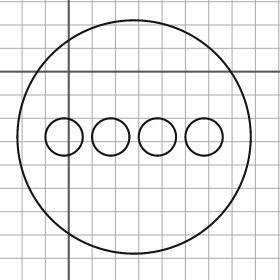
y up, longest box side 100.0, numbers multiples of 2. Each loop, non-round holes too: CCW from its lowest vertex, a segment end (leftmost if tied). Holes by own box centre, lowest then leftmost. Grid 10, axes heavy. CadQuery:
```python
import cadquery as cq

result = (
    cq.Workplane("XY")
    .moveTo(28.0, -28.0)
    .circle(50.0)
    .moveTo(-2.0, -28.0)
    .circle(8.0)
    .moveTo(18.0, -28.0)
    .circle(8.0)
    .moveTo(38.0, -28.0)
    .circle(8.0)
    .moveTo(58.0, -28.0)
    .circle(8.0)
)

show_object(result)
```